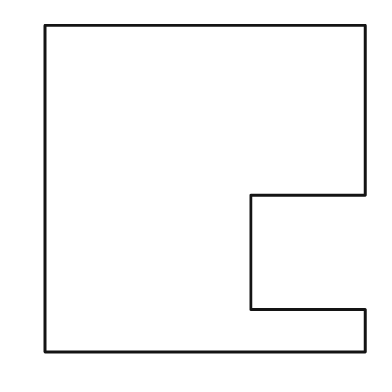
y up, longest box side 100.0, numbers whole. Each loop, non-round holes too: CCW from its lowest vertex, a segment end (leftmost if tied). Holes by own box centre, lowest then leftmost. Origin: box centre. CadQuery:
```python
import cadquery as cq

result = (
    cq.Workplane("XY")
    .moveTo(-49.0, -50.0)
    .lineTo(49.0, -50.0)
    .lineTo(49.0, -37.0)
    .lineTo(14.0, -37.0)
    .lineTo(14.0, -2.0)
    .lineTo(49.0, -2.0)
    .lineTo(49.0, 50.0)
    .lineTo(-49.0, 50.0)
    .close()
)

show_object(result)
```